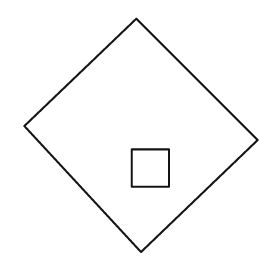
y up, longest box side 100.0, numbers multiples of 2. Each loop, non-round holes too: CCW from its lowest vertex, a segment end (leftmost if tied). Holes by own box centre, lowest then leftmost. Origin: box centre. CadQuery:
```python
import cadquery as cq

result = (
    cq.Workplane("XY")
    .moveTo(0.0, -50.0)
    .lineTo(50.0, -2.0)
    .lineTo(-2.0, 50.0)
    .lineTo(-50.0, 4.0)
    .close()
    .moveTo(-4.0, -22.0)
    .lineTo(12.0, -22.0)
    .lineTo(12.0, -6.0)
    .lineTo(-4.0, -6.0)
    .close()
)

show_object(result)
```